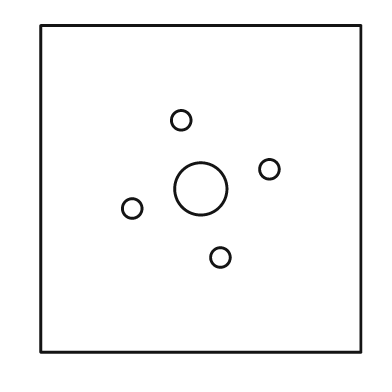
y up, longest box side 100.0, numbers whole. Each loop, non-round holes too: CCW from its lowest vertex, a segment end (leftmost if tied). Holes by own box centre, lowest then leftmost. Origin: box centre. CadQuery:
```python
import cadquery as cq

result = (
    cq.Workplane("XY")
    .moveTo(-49.0, -50.0)
    .lineTo(49.0, -50.0)
    .lineTo(49.0, 50.0)
    .lineTo(-49.0, 50.0)
    .close()
    .moveTo(6.0, -21.0)
    .circle(3.0)
    .moveTo(-21.0, -6.0)
    .circle(3.0)
    .moveTo(0.0, 0.0)
    .circle(8.0)
    .moveTo(21.0, 6.0)
    .circle(3.0)
    .moveTo(-6.0, 21.0)
    .circle(3.0)
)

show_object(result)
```